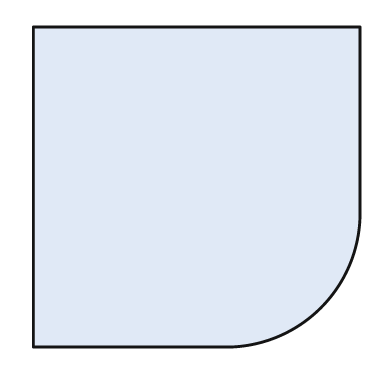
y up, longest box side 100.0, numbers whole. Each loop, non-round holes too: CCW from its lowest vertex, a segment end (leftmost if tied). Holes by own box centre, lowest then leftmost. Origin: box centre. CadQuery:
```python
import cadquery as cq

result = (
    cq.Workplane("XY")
    .moveTo(-50.0, -49.0)
    .lineTo(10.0, -49.0)
    .threePointArc((38.0, -37.0), (50.0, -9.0))
    .lineTo(50.0, 49.0)
    .lineTo(-50.0, 49.0)
    .close()
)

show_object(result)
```